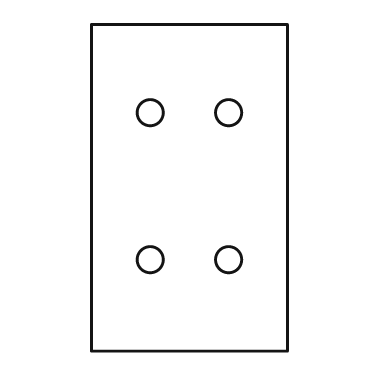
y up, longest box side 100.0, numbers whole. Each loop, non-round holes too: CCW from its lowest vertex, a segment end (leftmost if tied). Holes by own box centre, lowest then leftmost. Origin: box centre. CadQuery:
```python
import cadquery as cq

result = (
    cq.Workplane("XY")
    .moveTo(-30.0, -50.0)
    .lineTo(30.0, -50.0)
    .lineTo(30.0, 50.0)
    .lineTo(-30.0, 50.0)
    .close()
    .moveTo(-12.0, -22.0)
    .circle(4.0)
    .moveTo(12.0, -22.0)
    .circle(4.0)
    .moveTo(-12.0, 23.0)
    .circle(4.0)
    .moveTo(12.0, 23.0)
    .circle(4.0)
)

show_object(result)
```